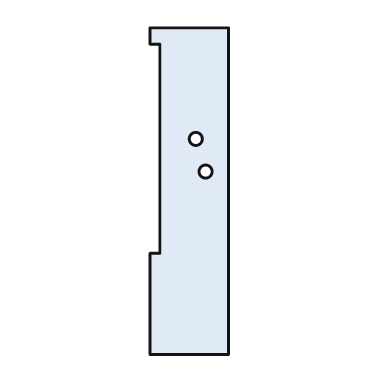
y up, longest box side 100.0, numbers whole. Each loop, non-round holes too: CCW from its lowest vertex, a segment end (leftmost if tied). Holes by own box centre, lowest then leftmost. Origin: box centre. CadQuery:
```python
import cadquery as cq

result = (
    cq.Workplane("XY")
    .moveTo(-12.0, -50.0)
    .lineTo(12.0, -50.0)
    .lineTo(12.0, 50.0)
    .lineTo(-12.0, 50.0)
    .lineTo(-12.0, 45.0)
    .lineTo(-9.0, 45.0)
    .lineTo(-9.0, -19.0)
    .lineTo(-12.0, -19.0)
    .close()
    .moveTo(5.0, 6.0)
    .circle(2.0)
    .moveTo(2.0, 16.0)
    .circle(2.0)
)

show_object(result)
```